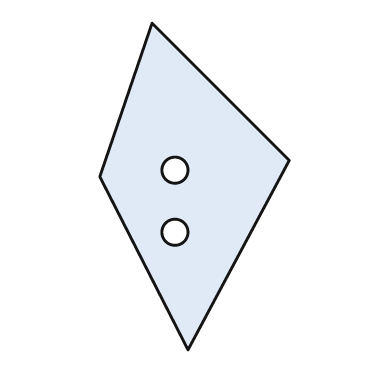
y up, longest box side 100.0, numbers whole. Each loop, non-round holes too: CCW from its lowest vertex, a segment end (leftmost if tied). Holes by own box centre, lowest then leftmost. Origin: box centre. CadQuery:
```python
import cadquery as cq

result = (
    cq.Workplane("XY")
    .moveTo(-2.0, -50.0)
    .lineTo(29.0, 8.0)
    .lineTo(-13.0, 50.0)
    .lineTo(-29.0, 3.0)
    .close()
    .moveTo(-6.0, -14.0)
    .circle(4.0)
    .moveTo(-6.0, 5.0)
    .circle(4.0)
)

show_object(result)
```